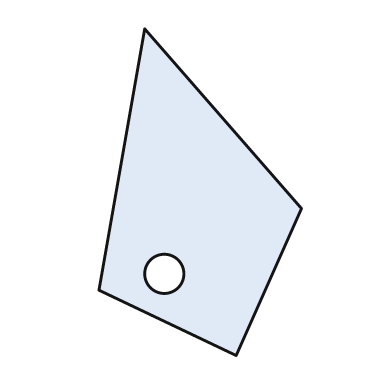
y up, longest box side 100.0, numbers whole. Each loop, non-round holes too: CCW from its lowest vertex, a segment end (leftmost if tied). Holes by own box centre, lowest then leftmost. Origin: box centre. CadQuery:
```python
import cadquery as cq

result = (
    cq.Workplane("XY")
    .moveTo(11.0, -50.0)
    .lineTo(31.0, -5.0)
    .lineTo(-17.0, 50.0)
    .lineTo(-31.0, -30.0)
    .close()
    .moveTo(-11.0, -25.0)
    .circle(6.0)
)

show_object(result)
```